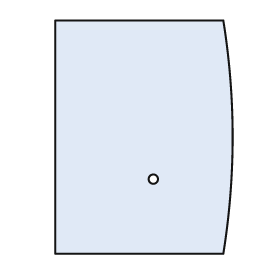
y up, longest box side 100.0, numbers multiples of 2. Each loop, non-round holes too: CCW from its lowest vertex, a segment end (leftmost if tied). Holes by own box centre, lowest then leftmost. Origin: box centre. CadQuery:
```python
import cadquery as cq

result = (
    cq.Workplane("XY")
    .moveTo(-38.0, -50.0)
    .lineTo(34.0, -50.0)
    .threePointArc((38.0, 0.0), (34.0, 50.0))
    .lineTo(-38.0, 50.0)
    .close()
    .moveTo(4.0, -18.0)
    .circle(2.0)
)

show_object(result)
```